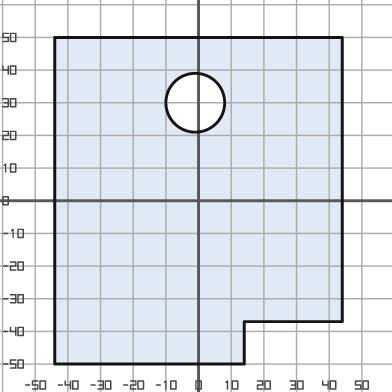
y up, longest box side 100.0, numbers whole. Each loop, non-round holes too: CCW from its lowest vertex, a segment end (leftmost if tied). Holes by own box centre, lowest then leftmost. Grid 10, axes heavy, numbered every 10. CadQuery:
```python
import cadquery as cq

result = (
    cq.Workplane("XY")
    .moveTo(-44.0, -50.0)
    .lineTo(14.0, -50.0)
    .lineTo(14.0, -37.0)
    .lineTo(44.0, -37.0)
    .lineTo(44.0, 50.0)
    .lineTo(-44.0, 50.0)
    .close()
    .moveTo(-1.0, 30.0)
    .circle(9.0)
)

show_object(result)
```